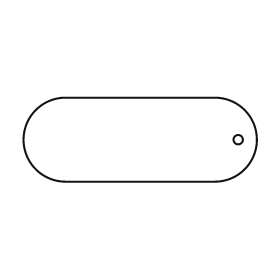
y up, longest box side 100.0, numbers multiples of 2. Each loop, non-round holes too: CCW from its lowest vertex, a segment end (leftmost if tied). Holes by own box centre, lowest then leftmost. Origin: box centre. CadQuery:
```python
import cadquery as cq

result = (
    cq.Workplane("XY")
    .moveTo(-32.0, -18.0)
    .lineTo(32.0, -18.0)
    .threePointArc((50.0, 0.0), (32.0, 18.0))
    .lineTo(-32.0, 18.0)
    .threePointArc((-50.0, 0.0), (-32.0, -18.0))
    .close()
    .moveTo(42.0, 0.0)
    .circle(2.0)
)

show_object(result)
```